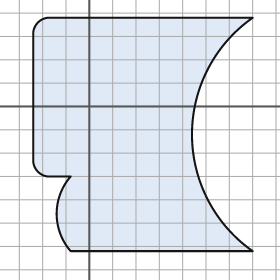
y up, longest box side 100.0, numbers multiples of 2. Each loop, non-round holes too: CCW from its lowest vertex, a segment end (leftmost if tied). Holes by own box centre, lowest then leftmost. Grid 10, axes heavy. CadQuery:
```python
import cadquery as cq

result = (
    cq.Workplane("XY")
    .moveTo(-8.0, -62.0)
    .lineTo(70.0, -62.0)
    .threePointArc((44.0, -12.0), (70.0, 38.0))
    .lineTo(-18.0, 38.0)
    .threePointArc((-22.0, 36.0), (-24.0, 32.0))
    .lineTo(-24.0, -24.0)
    .threePointArc((-22.0, -28.0), (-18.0, -30.0))
    .lineTo(-8.0, -30.0)
    .threePointArc((-14.0, -46.0), (-8.0, -62.0))
    .close()
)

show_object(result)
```